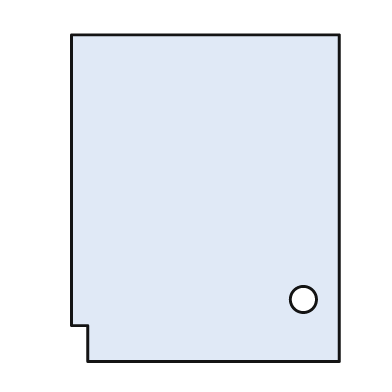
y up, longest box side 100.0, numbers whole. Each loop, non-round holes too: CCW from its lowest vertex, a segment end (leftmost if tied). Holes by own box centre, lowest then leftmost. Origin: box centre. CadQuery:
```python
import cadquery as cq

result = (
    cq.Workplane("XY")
    .moveTo(-36.0, -50.0)
    .lineTo(41.0, -50.0)
    .lineTo(41.0, 50.0)
    .lineTo(-41.0, 50.0)
    .lineTo(-41.0, -39.0)
    .lineTo(-36.0, -39.0)
    .close()
    .moveTo(30.0, -31.0)
    .circle(4.0)
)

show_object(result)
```